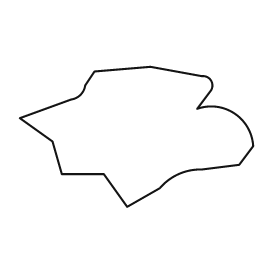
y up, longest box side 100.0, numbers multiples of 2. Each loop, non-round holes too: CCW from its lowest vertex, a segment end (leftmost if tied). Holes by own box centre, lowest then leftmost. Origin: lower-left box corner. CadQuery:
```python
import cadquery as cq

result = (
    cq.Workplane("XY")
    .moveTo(46.0, 0.0)
    .lineTo(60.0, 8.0)
    .threePointArc((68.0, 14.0), (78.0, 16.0))
    .lineTo(94.0, 18.0)
    .lineTo(100.0, 26.0)
    .threePointArc((92.0, 40.0), (76.0, 42.0))
    .lineTo(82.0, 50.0)
    .threePointArc((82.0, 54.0), (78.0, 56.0))
    .lineTo(56.0, 60.0)
    .lineTo(32.0, 58.0)
    .lineTo(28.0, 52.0)
    .threePointArc((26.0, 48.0), (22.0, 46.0))
    .lineTo(0.0, 38.0)
    .lineTo(14.0, 28.0)
    .lineTo(18.0, 14.0)
    .lineTo(36.0, 14.0)
    .close()
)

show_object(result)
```